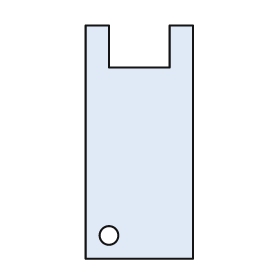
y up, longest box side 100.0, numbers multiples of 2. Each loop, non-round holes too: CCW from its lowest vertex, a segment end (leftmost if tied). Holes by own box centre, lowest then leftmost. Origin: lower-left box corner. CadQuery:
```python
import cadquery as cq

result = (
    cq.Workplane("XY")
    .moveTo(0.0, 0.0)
    .lineTo(46.0, 0.0)
    .lineTo(46.0, 100.0)
    .lineTo(36.0, 100.0)
    .lineTo(36.0, 82.0)
    .lineTo(10.0, 82.0)
    .lineTo(10.0, 100.0)
    .lineTo(0.0, 100.0)
    .close()
    .moveTo(10.0, 10.0)
    .circle(4.0)
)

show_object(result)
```